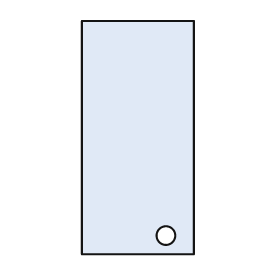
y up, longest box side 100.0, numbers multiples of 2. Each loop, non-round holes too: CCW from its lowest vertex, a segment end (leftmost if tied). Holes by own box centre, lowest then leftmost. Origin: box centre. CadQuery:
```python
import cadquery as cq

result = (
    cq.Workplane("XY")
    .moveTo(-24.0, -50.0)
    .lineTo(24.0, -50.0)
    .lineTo(24.0, 50.0)
    .lineTo(-24.0, 50.0)
    .close()
    .moveTo(12.0, -42.0)
    .circle(4.0)
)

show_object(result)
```